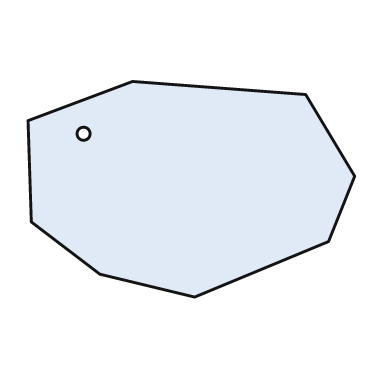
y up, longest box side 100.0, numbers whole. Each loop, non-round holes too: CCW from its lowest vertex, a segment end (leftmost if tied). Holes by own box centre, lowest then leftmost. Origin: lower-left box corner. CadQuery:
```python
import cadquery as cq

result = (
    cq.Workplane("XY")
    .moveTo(51.0, 0.0)
    .lineTo(92.0, 17.0)
    .lineTo(100.0, 37.0)
    .lineTo(85.0, 62.0)
    .lineTo(32.0, 66.0)
    .lineTo(0.0, 54.0)
    .lineTo(1.0, 23.0)
    .lineTo(22.0, 7.0)
    .close()
    .moveTo(17.0, 50.0)
    .circle(2.0)
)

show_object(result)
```